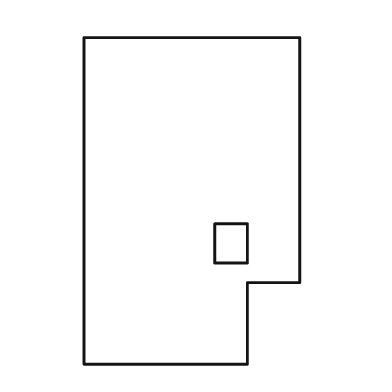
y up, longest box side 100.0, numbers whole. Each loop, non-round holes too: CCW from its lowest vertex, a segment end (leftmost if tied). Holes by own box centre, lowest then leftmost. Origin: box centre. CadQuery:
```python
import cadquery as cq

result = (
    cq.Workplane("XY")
    .moveTo(-33.0, -50.0)
    .lineTo(17.0, -50.0)
    .lineTo(17.0, -25.0)
    .lineTo(33.0, -25.0)
    .lineTo(33.0, 50.0)
    .lineTo(-33.0, 50.0)
    .close()
    .moveTo(7.0, -19.0)
    .lineTo(17.0, -19.0)
    .lineTo(17.0, -7.0)
    .lineTo(7.0, -7.0)
    .close()
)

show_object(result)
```